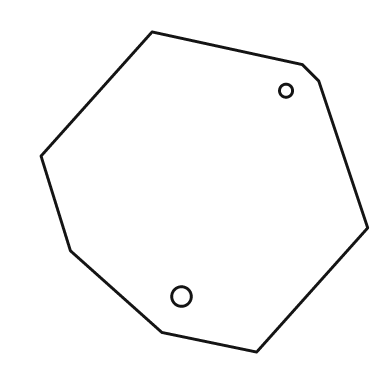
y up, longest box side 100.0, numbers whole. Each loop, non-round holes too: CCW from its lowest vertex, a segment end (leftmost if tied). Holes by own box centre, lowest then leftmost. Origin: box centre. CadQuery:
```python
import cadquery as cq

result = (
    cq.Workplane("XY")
    .moveTo(16.0, -49.0)
    .lineTo(50.0, -11.0)
    .lineTo(35.0, 34.0)
    .lineTo(30.0, 39.0)
    .lineTo(-16.0, 49.0)
    .lineTo(-50.0, 11.0)
    .lineTo(-41.0, -18.0)
    .lineTo(-13.0, -43.0)
    .close()
    .moveTo(-7.0, -32.0)
    .circle(3.0)
    .moveTo(25.0, 31.0)
    .circle(2.0)
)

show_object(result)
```